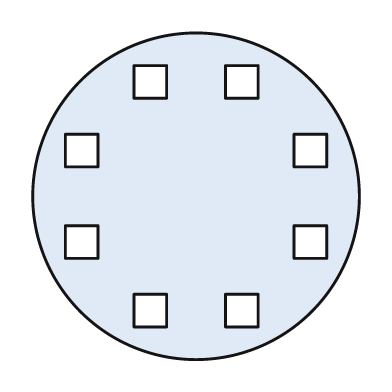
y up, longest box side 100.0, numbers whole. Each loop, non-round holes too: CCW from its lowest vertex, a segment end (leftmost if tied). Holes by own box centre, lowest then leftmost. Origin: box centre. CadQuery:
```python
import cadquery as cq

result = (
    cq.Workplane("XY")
    .moveTo(0.0, 0.0)
    .circle(50.0)
    .moveTo(-19.0, -40.0)
    .lineTo(-9.0, -40.0)
    .lineTo(-9.0, -30.0)
    .lineTo(-19.0, -30.0)
    .close()
    .moveTo(9.0, -40.0)
    .lineTo(19.0, -40.0)
    .lineTo(19.0, -30.0)
    .lineTo(9.0, -30.0)
    .close()
    .moveTo(-40.0, -19.0)
    .lineTo(-30.0, -19.0)
    .lineTo(-30.0, -9.0)
    .lineTo(-40.0, -9.0)
    .close()
    .moveTo(30.0, -19.0)
    .lineTo(40.0, -19.0)
    .lineTo(40.0, -9.0)
    .lineTo(30.0, -9.0)
    .close()
    .moveTo(-40.0, 9.0)
    .lineTo(-30.0, 9.0)
    .lineTo(-30.0, 19.0)
    .lineTo(-40.0, 19.0)
    .close()
    .moveTo(30.0, 9.0)
    .lineTo(40.0, 9.0)
    .lineTo(40.0, 19.0)
    .lineTo(30.0, 19.0)
    .close()
    .moveTo(-19.0, 30.0)
    .lineTo(-9.0, 30.0)
    .lineTo(-9.0, 40.0)
    .lineTo(-19.0, 40.0)
    .close()
    .moveTo(9.0, 30.0)
    .lineTo(19.0, 30.0)
    .lineTo(19.0, 40.0)
    .lineTo(9.0, 40.0)
    .close()
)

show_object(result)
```